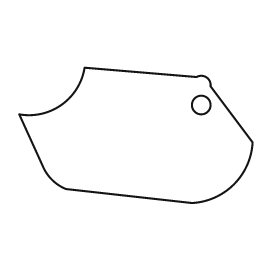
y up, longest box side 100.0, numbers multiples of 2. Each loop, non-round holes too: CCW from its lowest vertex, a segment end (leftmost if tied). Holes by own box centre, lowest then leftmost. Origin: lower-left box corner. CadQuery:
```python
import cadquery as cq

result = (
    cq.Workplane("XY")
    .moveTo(74.0, 0.0)
    .threePointArc((92.0, 8.0), (100.0, 26.0))
    .lineTo(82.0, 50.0)
    .threePointArc((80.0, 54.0), (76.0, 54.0))
    .lineTo(28.0, 58.0)
    .threePointArc((18.0, 42.0), (0.0, 38.0))
    .lineTo(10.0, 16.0)
    .threePointArc((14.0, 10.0), (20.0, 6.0))
    .close()
    .moveTo(78.0, 42.0)
    .circle(4.0)
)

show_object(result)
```